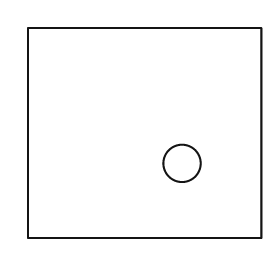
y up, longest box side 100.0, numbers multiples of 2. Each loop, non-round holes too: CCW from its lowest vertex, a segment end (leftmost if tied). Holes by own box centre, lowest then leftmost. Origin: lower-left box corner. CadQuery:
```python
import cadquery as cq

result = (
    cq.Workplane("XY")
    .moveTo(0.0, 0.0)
    .lineTo(100.0, 0.0)
    .lineTo(100.0, 90.0)
    .lineTo(0.0, 90.0)
    .close()
    .moveTo(66.0, 32.0)
    .circle(8.0)
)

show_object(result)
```